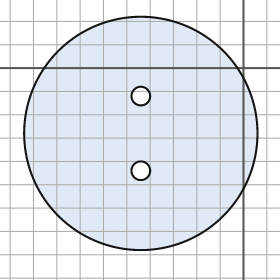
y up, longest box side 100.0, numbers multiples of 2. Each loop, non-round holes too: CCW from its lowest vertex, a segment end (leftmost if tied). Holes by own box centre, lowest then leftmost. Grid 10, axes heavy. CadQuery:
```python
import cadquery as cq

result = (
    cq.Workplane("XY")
    .moveTo(-44.0, -28.0)
    .circle(50.0)
    .moveTo(-44.0, -44.0)
    .circle(4.0)
    .moveTo(-44.0, -12.0)
    .circle(4.0)
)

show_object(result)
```